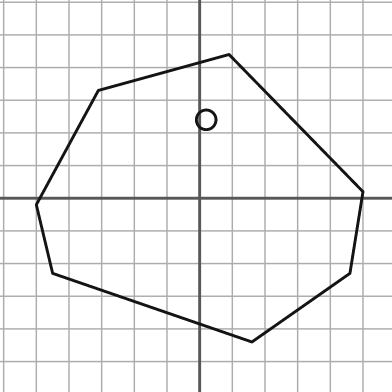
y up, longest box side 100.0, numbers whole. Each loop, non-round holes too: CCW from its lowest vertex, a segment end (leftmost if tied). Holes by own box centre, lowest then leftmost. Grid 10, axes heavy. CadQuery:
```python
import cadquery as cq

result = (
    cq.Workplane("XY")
    .moveTo(16.0, -44.0)
    .lineTo(46.0, -23.0)
    .lineTo(50.0, 2.0)
    .lineTo(9.0, 44.0)
    .lineTo(-31.0, 33.0)
    .lineTo(-50.0, -2.0)
    .lineTo(-45.0, -23.0)
    .close()
    .moveTo(2.0, 24.0)
    .circle(3.0)
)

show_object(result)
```